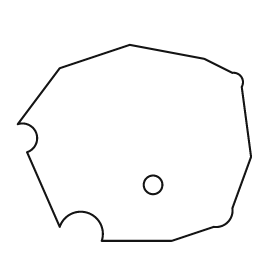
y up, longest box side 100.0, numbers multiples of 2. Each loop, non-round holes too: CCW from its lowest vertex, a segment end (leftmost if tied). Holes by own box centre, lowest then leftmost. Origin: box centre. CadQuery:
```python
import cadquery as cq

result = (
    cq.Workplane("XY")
    .moveTo(-14.0, -42.0)
    .lineTo(16.0, -42.0)
    .lineTo(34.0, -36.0)
    .threePointArc((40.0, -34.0), (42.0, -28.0))
    .lineTo(50.0, -6.0)
    .lineTo(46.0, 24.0)
    .threePointArc((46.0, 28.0), (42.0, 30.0))
    .lineTo(30.0, 36.0)
    .lineTo(-2.0, 42.0)
    .lineTo(-32.0, 32.0)
    .lineTo(-50.0, 8.0)
    .threePointArc((-42.0, 4.0), (-46.0, -4.0))
    .lineTo(-32.0, -36.0)
    .threePointArc((-20.0, -30.0), (-14.0, -42.0))
    .close()
    .moveTo(8.0, -18.0)
    .circle(4.0)
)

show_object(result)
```